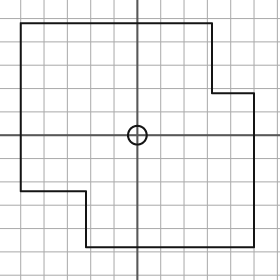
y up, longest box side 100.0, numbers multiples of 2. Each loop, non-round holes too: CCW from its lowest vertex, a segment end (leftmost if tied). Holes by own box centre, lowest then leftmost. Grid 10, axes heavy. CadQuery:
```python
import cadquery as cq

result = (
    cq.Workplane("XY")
    .moveTo(-22.0, -48.0)
    .lineTo(50.0, -48.0)
    .lineTo(50.0, 18.0)
    .lineTo(32.0, 18.0)
    .lineTo(32.0, 48.0)
    .lineTo(-50.0, 48.0)
    .lineTo(-50.0, -24.0)
    .lineTo(-22.0, -24.0)
    .close()
    .moveTo(0.0, 0.0)
    .circle(4.0)
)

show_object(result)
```